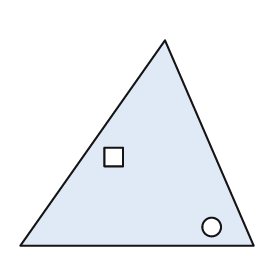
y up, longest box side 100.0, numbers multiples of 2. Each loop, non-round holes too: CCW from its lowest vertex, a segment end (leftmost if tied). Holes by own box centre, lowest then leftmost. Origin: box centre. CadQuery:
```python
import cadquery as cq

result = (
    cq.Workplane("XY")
    .moveTo(-50.0, -44.0)
    .lineTo(50.0, -44.0)
    .lineTo(12.0, 44.0)
    .close()
    .moveTo(32.0, -36.0)
    .circle(4.0)
    .moveTo(-14.0, -10.0)
    .lineTo(-6.0, -10.0)
    .lineTo(-6.0, -2.0)
    .lineTo(-14.0, -2.0)
    .close()
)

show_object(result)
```